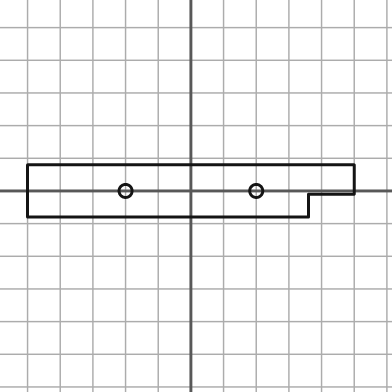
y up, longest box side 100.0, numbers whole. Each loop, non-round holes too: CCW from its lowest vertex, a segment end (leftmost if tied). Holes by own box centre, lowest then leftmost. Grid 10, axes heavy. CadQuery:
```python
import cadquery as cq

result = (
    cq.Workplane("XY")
    .moveTo(-50.0, -8.0)
    .lineTo(36.0, -8.0)
    .lineTo(36.0, -1.0)
    .lineTo(50.0, -1.0)
    .lineTo(50.0, 8.0)
    .lineTo(-50.0, 8.0)
    .close()
    .moveTo(-20.0, 0.0)
    .circle(2.0)
    .moveTo(20.0, 0.0)
    .circle(2.0)
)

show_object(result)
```